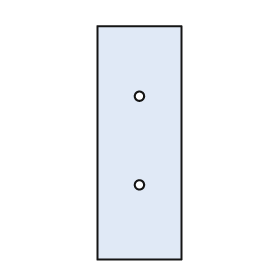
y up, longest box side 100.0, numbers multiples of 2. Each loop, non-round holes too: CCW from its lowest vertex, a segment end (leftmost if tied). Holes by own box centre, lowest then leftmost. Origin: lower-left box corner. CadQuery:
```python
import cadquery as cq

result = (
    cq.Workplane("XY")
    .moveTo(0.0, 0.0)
    .lineTo(36.0, 0.0)
    .lineTo(36.0, 100.0)
    .lineTo(0.0, 100.0)
    .close()
    .moveTo(18.0, 32.0)
    .circle(2.0)
    .moveTo(18.0, 70.0)
    .circle(2.0)
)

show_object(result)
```